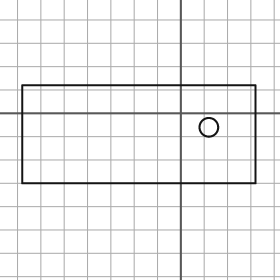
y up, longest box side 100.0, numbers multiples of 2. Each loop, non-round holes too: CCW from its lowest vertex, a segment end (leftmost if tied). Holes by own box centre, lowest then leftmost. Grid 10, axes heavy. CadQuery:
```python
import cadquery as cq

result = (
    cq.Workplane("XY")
    .moveTo(-68.0, -30.0)
    .lineTo(32.0, -30.0)
    .lineTo(32.0, 12.0)
    .lineTo(-68.0, 12.0)
    .close()
    .moveTo(12.0, -6.0)
    .circle(4.0)
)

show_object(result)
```